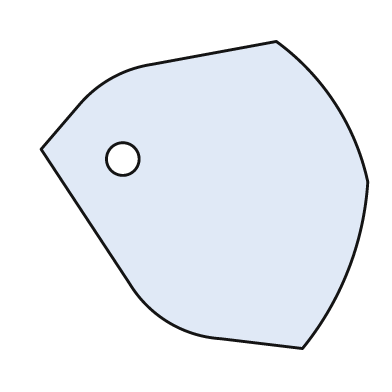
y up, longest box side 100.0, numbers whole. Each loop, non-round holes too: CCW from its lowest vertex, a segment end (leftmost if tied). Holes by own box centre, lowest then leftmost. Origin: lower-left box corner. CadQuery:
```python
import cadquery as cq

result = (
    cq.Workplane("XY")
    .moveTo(80.0, 0.0)
    .threePointArc((94.0, 24.0), (100.0, 51.0))
    .threePointArc((90.0, 75.0), (72.0, 94.0))
    .lineTo(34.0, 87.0)
    .threePointArc((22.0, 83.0), (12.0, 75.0))
    .lineTo(0.0, 61.0)
    .lineTo(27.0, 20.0)
    .threePointArc((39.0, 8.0), (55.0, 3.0))
    .close()
    .moveTo(25.0, 58.0)
    .circle(5.0)
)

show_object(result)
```